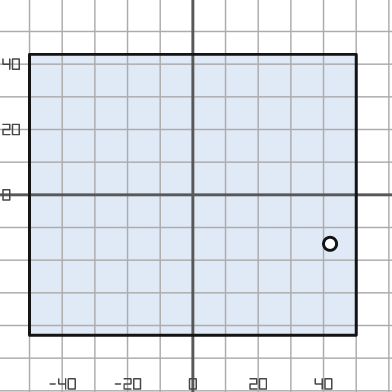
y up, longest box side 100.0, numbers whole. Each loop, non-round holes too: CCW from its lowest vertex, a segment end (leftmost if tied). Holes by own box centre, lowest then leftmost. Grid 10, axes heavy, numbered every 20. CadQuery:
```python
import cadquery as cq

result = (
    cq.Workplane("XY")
    .moveTo(-50.0, -43.0)
    .lineTo(50.0, -43.0)
    .lineTo(50.0, 43.0)
    .lineTo(-50.0, 43.0)
    .close()
    .moveTo(42.0, -15.0)
    .circle(2.0)
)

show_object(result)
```